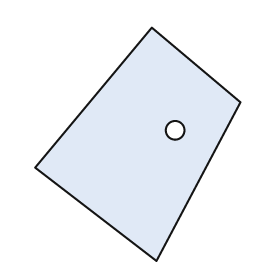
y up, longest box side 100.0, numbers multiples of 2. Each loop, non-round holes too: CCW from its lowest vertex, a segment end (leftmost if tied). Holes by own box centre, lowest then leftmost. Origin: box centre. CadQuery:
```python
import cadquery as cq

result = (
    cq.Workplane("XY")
    .moveTo(8.0, -50.0)
    .lineTo(44.0, 18.0)
    .lineTo(6.0, 50.0)
    .lineTo(-44.0, -10.0)
    .close()
    .moveTo(16.0, 6.0)
    .circle(4.0)
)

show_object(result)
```